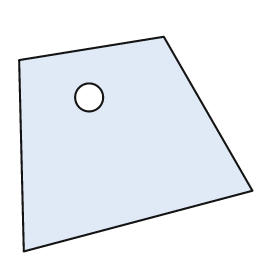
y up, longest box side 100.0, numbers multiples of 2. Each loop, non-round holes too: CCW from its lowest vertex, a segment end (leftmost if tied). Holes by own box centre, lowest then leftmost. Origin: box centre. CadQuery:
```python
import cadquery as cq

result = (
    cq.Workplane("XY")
    .moveTo(-48.0, -46.0)
    .lineTo(50.0, -20.0)
    .lineTo(12.0, 46.0)
    .lineTo(-50.0, 36.0)
    .close()
    .moveTo(-20.0, 20.0)
    .circle(6.0)
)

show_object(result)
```